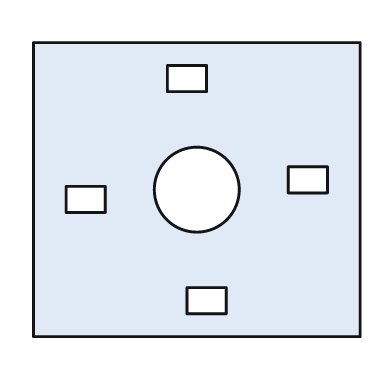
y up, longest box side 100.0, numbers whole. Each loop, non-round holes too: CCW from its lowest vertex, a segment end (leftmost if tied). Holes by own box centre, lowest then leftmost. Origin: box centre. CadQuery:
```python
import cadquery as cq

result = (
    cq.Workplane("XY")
    .moveTo(-50.0, -45.0)
    .lineTo(50.0, -45.0)
    .lineTo(50.0, 45.0)
    .lineTo(-50.0, 45.0)
    .close()
    .moveTo(-3.0, -38.0)
    .lineTo(9.0, -38.0)
    .lineTo(9.0, -30.0)
    .lineTo(-3.0, -30.0)
    .close()
    .moveTo(-40.0, -7.0)
    .lineTo(-28.0, -7.0)
    .lineTo(-28.0, 1.0)
    .lineTo(-40.0, 1.0)
    .close()
    .moveTo(0.0, 0.0)
    .circle(13.0)
    .moveTo(28.0, -1.0)
    .lineTo(40.0, -1.0)
    .lineTo(40.0, 7.0)
    .lineTo(28.0, 7.0)
    .close()
    .moveTo(-9.0, 30.0)
    .lineTo(3.0, 30.0)
    .lineTo(3.0, 38.0)
    .lineTo(-9.0, 38.0)
    .close()
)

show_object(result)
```